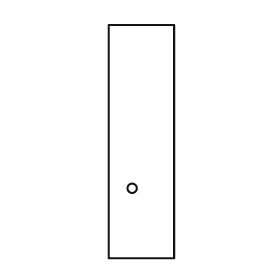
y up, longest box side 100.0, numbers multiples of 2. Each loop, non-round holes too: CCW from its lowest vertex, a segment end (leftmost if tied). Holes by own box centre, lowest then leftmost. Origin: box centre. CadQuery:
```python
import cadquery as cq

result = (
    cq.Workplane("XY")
    .moveTo(-14.0, -50.0)
    .lineTo(14.0, -50.0)
    .lineTo(14.0, 50.0)
    .lineTo(-14.0, 50.0)
    .close()
    .moveTo(-4.0, -20.0)
    .circle(2.0)
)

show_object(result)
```